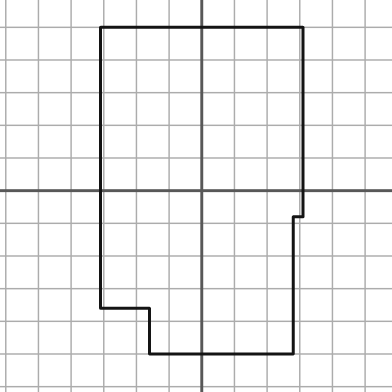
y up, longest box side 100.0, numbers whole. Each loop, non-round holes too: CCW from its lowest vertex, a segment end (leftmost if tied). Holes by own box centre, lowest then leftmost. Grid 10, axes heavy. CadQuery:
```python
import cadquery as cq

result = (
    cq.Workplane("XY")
    .moveTo(-16.0, -50.0)
    .lineTo(28.0, -50.0)
    .lineTo(28.0, -8.0)
    .lineTo(31.0, -8.0)
    .lineTo(31.0, 50.0)
    .lineTo(-31.0, 50.0)
    .lineTo(-31.0, -36.0)
    .lineTo(-16.0, -36.0)
    .close()
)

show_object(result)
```